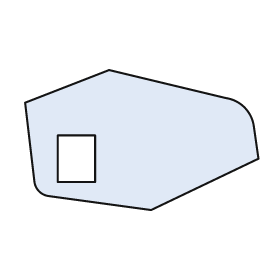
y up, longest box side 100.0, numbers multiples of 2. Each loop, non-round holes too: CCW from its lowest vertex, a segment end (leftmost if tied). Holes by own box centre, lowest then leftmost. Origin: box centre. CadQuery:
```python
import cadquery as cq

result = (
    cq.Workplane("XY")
    .moveTo(4.0, -30.0)
    .lineTo(50.0, -8.0)
    .lineTo(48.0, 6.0)
    .threePointArc((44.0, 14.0), (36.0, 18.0))
    .lineTo(-14.0, 30.0)
    .lineTo(-50.0, 16.0)
    .lineTo(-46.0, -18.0)
    .threePointArc((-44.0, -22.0), (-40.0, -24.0))
    .close()
    .moveTo(-36.0, -18.0)
    .lineTo(-20.0, -18.0)
    .lineTo(-20.0, 2.0)
    .lineTo(-36.0, 2.0)
    .close()
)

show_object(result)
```